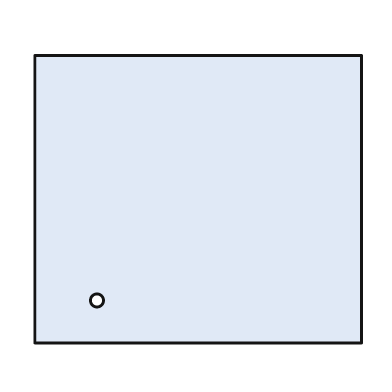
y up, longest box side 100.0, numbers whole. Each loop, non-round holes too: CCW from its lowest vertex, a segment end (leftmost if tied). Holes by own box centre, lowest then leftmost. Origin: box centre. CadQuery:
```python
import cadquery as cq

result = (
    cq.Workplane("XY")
    .moveTo(-50.0, -44.0)
    .lineTo(50.0, -44.0)
    .lineTo(50.0, 44.0)
    .lineTo(-50.0, 44.0)
    .close()
    .moveTo(-31.0, -31.0)
    .circle(2.0)
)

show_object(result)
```